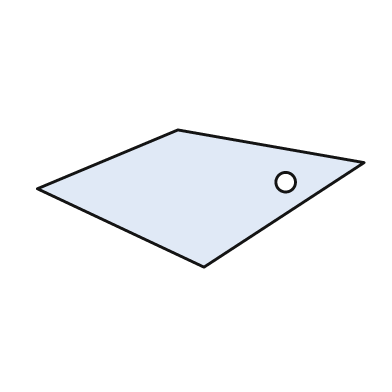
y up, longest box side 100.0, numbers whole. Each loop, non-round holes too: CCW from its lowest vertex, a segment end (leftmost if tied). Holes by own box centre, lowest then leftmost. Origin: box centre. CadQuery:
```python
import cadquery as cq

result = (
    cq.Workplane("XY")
    .moveTo(1.0, -21.0)
    .lineTo(50.0, 11.0)
    .lineTo(-7.0, 21.0)
    .lineTo(-50.0, 3.0)
    .close()
    .moveTo(26.0, 5.0)
    .circle(3.0)
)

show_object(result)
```